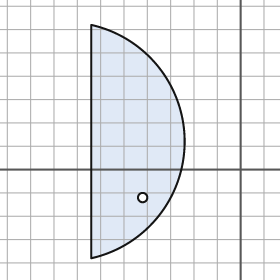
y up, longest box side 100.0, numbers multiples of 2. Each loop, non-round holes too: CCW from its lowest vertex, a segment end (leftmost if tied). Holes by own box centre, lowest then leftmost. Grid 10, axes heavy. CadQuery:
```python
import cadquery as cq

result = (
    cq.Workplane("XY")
    .moveTo(-64.0, -38.0)
    .threePointArc((-24.0, 12.0), (-64.0, 62.0))
    .close()
    .moveTo(-42.0, -12.0)
    .circle(2.0)
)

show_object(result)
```